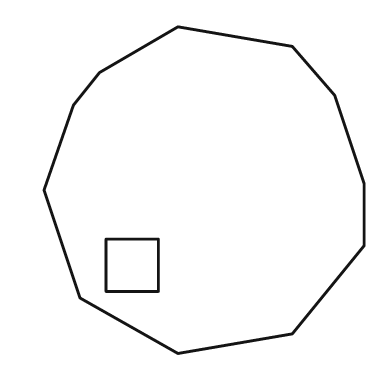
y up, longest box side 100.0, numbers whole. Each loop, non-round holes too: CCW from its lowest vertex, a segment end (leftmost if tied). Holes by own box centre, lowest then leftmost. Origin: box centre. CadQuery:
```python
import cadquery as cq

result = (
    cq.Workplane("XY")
    .moveTo(-8.0, -50.0)
    .lineTo(27.0, -44.0)
    .lineTo(49.0, -17.0)
    .lineTo(49.0, 2.0)
    .lineTo(40.0, 29.0)
    .lineTo(27.0, 44.0)
    .lineTo(-8.0, 50.0)
    .lineTo(-32.0, 36.0)
    .lineTo(-40.0, 26.0)
    .lineTo(-49.0, 0.0)
    .lineTo(-38.0, -33.0)
    .close()
    .moveTo(-30.0, -31.0)
    .lineTo(-14.0, -31.0)
    .lineTo(-14.0, -15.0)
    .lineTo(-30.0, -15.0)
    .close()
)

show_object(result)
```